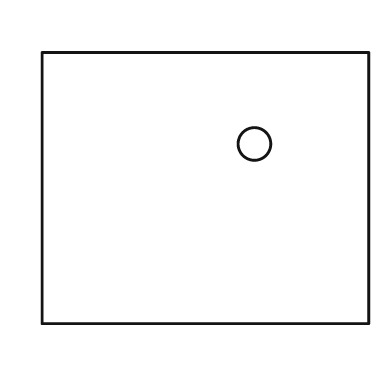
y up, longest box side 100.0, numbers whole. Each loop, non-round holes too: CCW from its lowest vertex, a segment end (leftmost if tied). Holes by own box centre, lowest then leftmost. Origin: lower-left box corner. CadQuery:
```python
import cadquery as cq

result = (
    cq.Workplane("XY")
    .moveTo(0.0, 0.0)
    .lineTo(100.0, 0.0)
    .lineTo(100.0, 83.0)
    .lineTo(0.0, 83.0)
    .close()
    .moveTo(65.0, 55.0)
    .circle(5.0)
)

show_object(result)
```